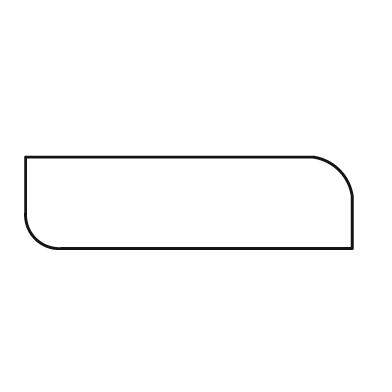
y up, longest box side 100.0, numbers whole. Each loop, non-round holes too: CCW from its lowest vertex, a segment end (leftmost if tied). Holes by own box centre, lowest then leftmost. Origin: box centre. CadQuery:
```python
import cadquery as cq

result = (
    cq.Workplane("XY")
    .moveTo(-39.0, -14.0)
    .lineTo(50.0, -14.0)
    .lineTo(50.0, 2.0)
    .threePointArc((46.0, 10.0), (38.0, 14.0))
    .lineTo(-50.0, 14.0)
    .lineTo(-50.0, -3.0)
    .threePointArc((-47.0, -11.0), (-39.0, -14.0))
    .close()
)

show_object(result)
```